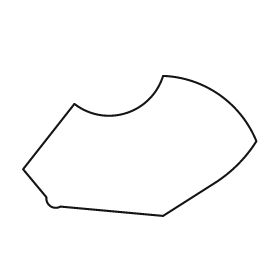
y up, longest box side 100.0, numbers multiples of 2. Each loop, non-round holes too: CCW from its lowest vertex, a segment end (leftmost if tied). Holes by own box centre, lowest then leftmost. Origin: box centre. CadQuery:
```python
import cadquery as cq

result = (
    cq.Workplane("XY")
    .moveTo(10.0, -30.0)
    .lineTo(32.0, -16.0)
    .threePointArc((42.0, -8.0), (50.0, 2.0))
    .threePointArc((34.0, 22.0), (10.0, 30.0))
    .threePointArc((-6.0, 14.0), (-28.0, 18.0))
    .lineTo(-50.0, -10.0)
    .lineTo(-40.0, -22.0)
    .threePointArc((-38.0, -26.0), (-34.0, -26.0))
    .close()
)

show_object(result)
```